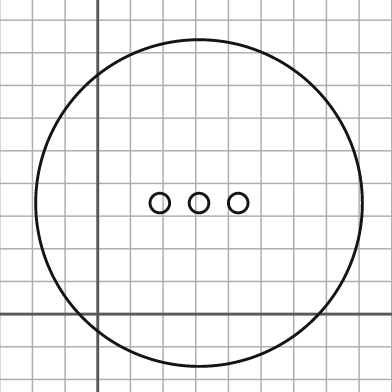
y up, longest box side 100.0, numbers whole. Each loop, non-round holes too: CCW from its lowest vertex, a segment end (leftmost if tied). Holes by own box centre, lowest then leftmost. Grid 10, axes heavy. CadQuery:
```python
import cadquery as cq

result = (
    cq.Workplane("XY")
    .moveTo(31.0, 34.0)
    .circle(50.0)
    .moveTo(19.0, 34.0)
    .circle(3.0)
    .moveTo(31.0, 34.0)
    .circle(3.0)
    .moveTo(43.0, 34.0)
    .circle(3.0)
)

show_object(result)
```